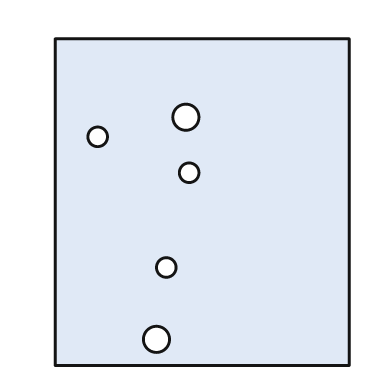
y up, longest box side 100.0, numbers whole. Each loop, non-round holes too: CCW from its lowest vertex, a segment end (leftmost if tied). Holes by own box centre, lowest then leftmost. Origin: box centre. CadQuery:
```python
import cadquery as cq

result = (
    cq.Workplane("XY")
    .moveTo(-45.0, -50.0)
    .lineTo(45.0, -50.0)
    .lineTo(45.0, 50.0)
    .lineTo(-45.0, 50.0)
    .close()
    .moveTo(-14.0, -42.0)
    .circle(4.0)
    .moveTo(-11.0, -20.0)
    .circle(3.0)
    .moveTo(-4.0, 9.0)
    .circle(3.0)
    .moveTo(-32.0, 20.0)
    .circle(3.0)
    .moveTo(-5.0, 26.0)
    .circle(4.0)
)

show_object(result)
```